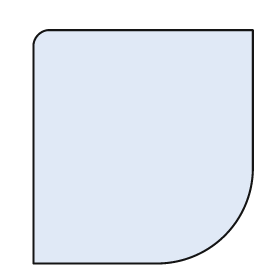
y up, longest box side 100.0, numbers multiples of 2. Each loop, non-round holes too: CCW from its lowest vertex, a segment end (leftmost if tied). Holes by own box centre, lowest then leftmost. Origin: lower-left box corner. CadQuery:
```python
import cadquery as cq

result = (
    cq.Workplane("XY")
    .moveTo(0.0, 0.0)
    .lineTo(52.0, 0.0)
    .threePointArc((82.0, 12.0), (94.0, 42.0))
    .lineTo(94.0, 100.0)
    .lineTo(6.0, 100.0)
    .threePointArc((2.0, 98.0), (0.0, 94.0))
    .close()
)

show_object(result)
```